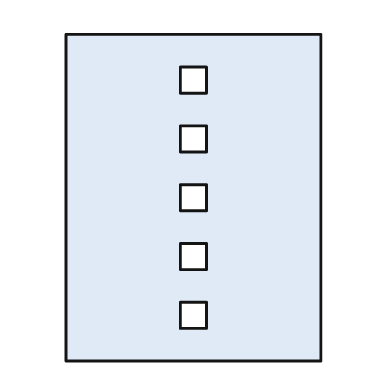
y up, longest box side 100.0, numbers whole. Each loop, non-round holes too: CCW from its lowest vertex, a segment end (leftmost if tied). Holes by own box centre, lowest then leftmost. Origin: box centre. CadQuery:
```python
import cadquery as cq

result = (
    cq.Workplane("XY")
    .moveTo(-39.0, -50.0)
    .lineTo(39.0, -50.0)
    .lineTo(39.0, 50.0)
    .lineTo(-39.0, 50.0)
    .close()
    .moveTo(-4.0, -40.0)
    .lineTo(4.0, -40.0)
    .lineTo(4.0, -32.0)
    .lineTo(-4.0, -32.0)
    .close()
    .moveTo(-4.0, -22.0)
    .lineTo(4.0, -22.0)
    .lineTo(4.0, -14.0)
    .lineTo(-4.0, -14.0)
    .close()
    .moveTo(-4.0, -4.0)
    .lineTo(4.0, -4.0)
    .lineTo(4.0, 4.0)
    .lineTo(-4.0, 4.0)
    .close()
    .moveTo(-4.0, 14.0)
    .lineTo(4.0, 14.0)
    .lineTo(4.0, 22.0)
    .lineTo(-4.0, 22.0)
    .close()
    .moveTo(-4.0, 32.0)
    .lineTo(4.0, 32.0)
    .lineTo(4.0, 40.0)
    .lineTo(-4.0, 40.0)
    .close()
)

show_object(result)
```